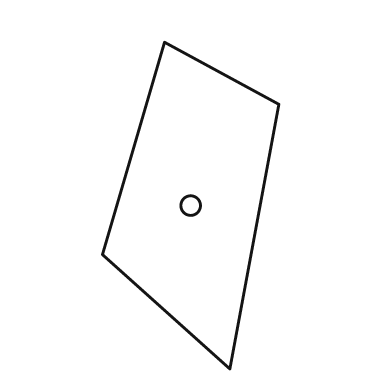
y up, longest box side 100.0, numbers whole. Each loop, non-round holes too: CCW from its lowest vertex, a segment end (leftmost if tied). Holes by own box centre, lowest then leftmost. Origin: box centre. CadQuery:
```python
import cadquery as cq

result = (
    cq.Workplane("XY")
    .moveTo(12.0, -50.0)
    .lineTo(27.0, 31.0)
    .lineTo(-8.0, 50.0)
    .lineTo(-27.0, -15.0)
    .close()
    .moveTo(0.0, 0.0)
    .circle(3.0)
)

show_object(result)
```